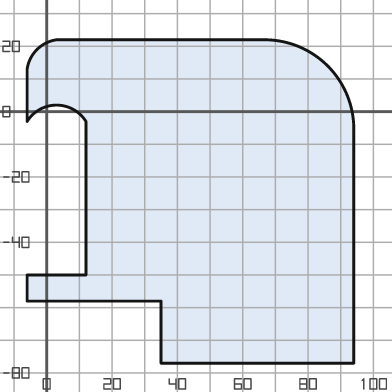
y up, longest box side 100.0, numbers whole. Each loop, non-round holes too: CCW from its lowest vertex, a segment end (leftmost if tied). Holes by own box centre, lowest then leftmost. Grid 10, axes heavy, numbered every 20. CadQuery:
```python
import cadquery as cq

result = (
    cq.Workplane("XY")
    .moveTo(35.0, -77.0)
    .lineTo(94.0, -77.0)
    .lineTo(94.0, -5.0)
    .threePointArc((86.0, 14.0), (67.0, 22.0))
    .lineTo(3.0, 22.0)
    .threePointArc((-3.0, 19.0), (-6.0, 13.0))
    .lineTo(-6.0, -3.0)
    .threePointArc((3.0, 2.0), (12.0, -3.0))
    .lineTo(12.0, -50.0)
    .lineTo(-6.0, -50.0)
    .lineTo(-6.0, -58.0)
    .lineTo(35.0, -58.0)
    .close()
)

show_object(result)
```